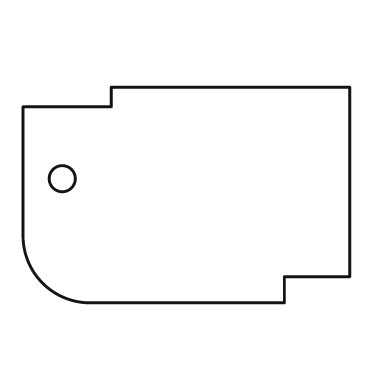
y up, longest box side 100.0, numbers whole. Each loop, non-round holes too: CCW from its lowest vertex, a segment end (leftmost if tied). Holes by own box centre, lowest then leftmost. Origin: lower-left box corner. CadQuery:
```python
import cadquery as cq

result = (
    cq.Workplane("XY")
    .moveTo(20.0, 0.0)
    .lineTo(80.0, 0.0)
    .lineTo(80.0, 8.0)
    .lineTo(100.0, 8.0)
    .lineTo(100.0, 66.0)
    .lineTo(27.0, 66.0)
    .lineTo(27.0, 60.0)
    .lineTo(0.0, 60.0)
    .lineTo(0.0, 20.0)
    .threePointArc((6.0, 6.0), (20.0, 0.0))
    .close()
    .moveTo(12.0, 38.0)
    .circle(4.0)
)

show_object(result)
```